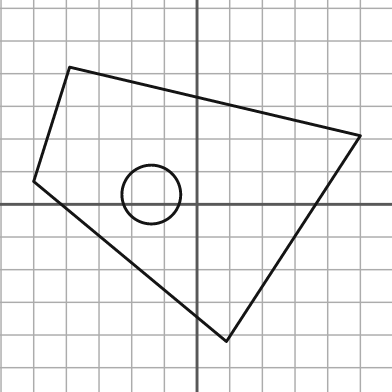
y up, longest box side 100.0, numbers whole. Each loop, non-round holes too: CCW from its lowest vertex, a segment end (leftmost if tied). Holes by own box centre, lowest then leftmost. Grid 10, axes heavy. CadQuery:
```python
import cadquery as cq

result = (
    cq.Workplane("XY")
    .moveTo(9.0, -42.0)
    .lineTo(50.0, 21.0)
    .lineTo(-39.0, 42.0)
    .lineTo(-50.0, 7.0)
    .close()
    .moveTo(-14.0, 3.0)
    .circle(9.0)
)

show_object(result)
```